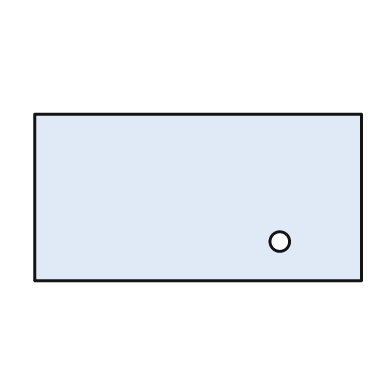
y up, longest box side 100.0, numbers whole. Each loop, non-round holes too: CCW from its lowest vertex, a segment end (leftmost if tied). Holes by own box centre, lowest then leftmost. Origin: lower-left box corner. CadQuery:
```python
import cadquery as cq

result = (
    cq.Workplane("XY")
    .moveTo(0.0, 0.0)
    .lineTo(100.0, 0.0)
    .lineTo(100.0, 51.0)
    .lineTo(0.0, 51.0)
    .close()
    .moveTo(75.0, 12.0)
    .circle(3.0)
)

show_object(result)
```